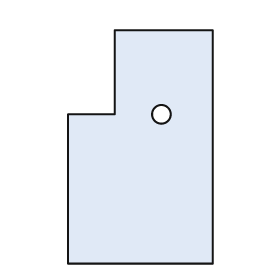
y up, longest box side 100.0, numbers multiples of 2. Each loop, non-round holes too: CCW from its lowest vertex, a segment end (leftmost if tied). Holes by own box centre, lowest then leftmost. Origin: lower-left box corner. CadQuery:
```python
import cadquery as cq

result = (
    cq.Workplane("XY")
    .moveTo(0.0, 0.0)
    .lineTo(62.0, 0.0)
    .lineTo(62.0, 100.0)
    .lineTo(20.0, 100.0)
    .lineTo(20.0, 64.0)
    .lineTo(0.0, 64.0)
    .close()
    .moveTo(40.0, 64.0)
    .circle(4.0)
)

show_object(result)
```